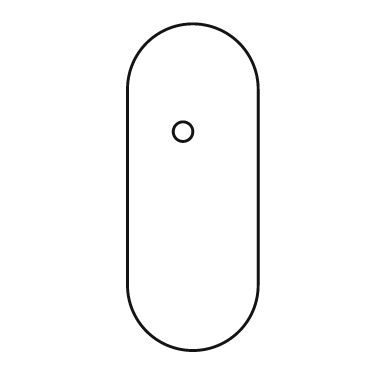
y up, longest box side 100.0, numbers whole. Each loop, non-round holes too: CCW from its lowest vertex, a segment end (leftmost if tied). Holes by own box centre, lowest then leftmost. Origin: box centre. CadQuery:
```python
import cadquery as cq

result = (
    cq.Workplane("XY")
    .moveTo(-20.0, -30.0)
    .threePointArc((0.0, -50.0), (20.0, -30.0))
    .lineTo(20.0, 30.0)
    .threePointArc((0.0, 50.0), (-20.0, 30.0))
    .close()
    .moveTo(-3.0, 17.0)
    .circle(3.0)
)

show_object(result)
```